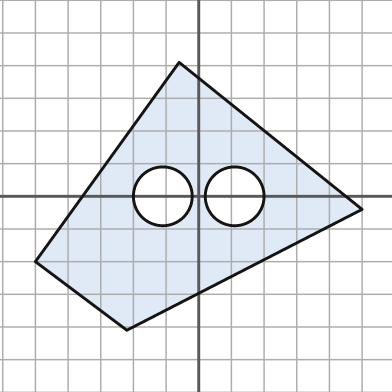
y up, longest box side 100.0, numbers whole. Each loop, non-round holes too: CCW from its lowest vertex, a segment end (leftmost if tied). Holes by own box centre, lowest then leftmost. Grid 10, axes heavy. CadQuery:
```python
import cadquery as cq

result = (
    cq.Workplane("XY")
    .moveTo(-22.0, -41.0)
    .lineTo(50.0, -4.0)
    .lineTo(-6.0, 41.0)
    .lineTo(-50.0, -20.0)
    .close()
    .moveTo(-11.0, 0.0)
    .circle(9.0)
    .moveTo(11.0, 0.0)
    .circle(9.0)
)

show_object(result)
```